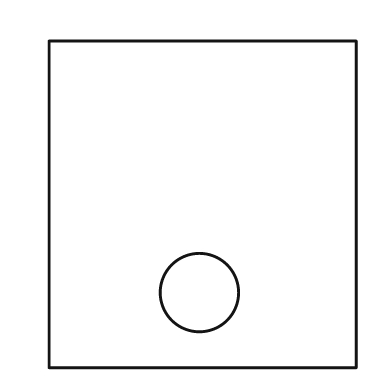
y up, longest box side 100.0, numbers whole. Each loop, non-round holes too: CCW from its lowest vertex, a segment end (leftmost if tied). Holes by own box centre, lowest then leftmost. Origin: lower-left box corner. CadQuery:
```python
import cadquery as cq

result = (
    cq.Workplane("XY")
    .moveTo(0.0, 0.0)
    .lineTo(94.0, 0.0)
    .lineTo(94.0, 100.0)
    .lineTo(0.0, 100.0)
    .close()
    .moveTo(46.0, 23.0)
    .circle(12.0)
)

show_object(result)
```